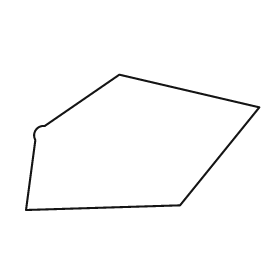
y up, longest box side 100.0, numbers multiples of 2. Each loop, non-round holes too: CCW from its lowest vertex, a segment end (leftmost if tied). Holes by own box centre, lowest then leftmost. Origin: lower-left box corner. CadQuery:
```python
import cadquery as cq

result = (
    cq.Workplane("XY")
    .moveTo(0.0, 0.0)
    .lineTo(66.0, 2.0)
    .lineTo(100.0, 44.0)
    .lineTo(40.0, 58.0)
    .lineTo(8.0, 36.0)
    .threePointArc((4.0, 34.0), (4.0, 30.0))
    .close()
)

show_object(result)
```